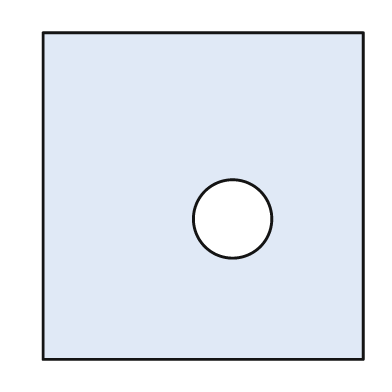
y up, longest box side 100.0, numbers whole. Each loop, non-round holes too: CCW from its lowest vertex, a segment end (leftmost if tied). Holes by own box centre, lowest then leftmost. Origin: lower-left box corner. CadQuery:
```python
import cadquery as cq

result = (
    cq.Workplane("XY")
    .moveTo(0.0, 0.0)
    .lineTo(98.0, 0.0)
    .lineTo(98.0, 100.0)
    .lineTo(0.0, 100.0)
    .close()
    .moveTo(58.0, 43.0)
    .circle(12.0)
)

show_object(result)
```